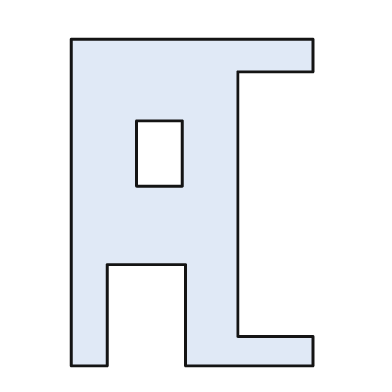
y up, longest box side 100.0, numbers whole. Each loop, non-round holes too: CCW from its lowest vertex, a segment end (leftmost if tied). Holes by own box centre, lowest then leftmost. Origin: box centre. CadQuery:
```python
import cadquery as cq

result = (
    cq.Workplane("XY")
    .moveTo(-37.0, -50.0)
    .lineTo(-26.0, -50.0)
    .lineTo(-26.0, -19.0)
    .lineTo(-2.0, -19.0)
    .lineTo(-2.0, -50.0)
    .lineTo(37.0, -50.0)
    .lineTo(37.0, -41.0)
    .lineTo(14.0, -41.0)
    .lineTo(14.0, 40.0)
    .lineTo(37.0, 40.0)
    .lineTo(37.0, 50.0)
    .lineTo(-37.0, 50.0)
    .close()
    .moveTo(-17.0, 5.0)
    .lineTo(-3.0, 5.0)
    .lineTo(-3.0, 25.0)
    .lineTo(-17.0, 25.0)
    .close()
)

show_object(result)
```